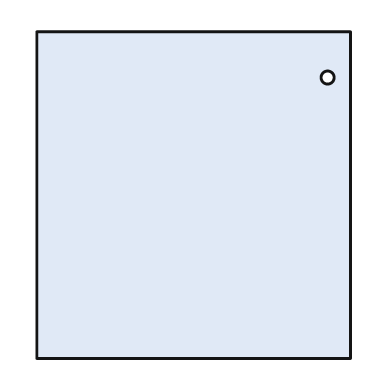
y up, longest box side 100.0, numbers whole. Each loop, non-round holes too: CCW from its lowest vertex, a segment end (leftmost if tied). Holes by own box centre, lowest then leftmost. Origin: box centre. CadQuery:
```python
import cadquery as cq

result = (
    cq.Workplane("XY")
    .moveTo(-48.0, -50.0)
    .lineTo(48.0, -50.0)
    .lineTo(48.0, 50.0)
    .lineTo(-48.0, 50.0)
    .close()
    .moveTo(41.0, 36.0)
    .circle(2.0)
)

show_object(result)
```